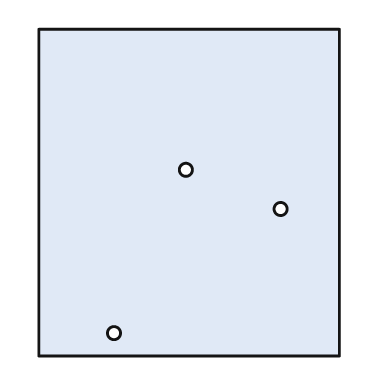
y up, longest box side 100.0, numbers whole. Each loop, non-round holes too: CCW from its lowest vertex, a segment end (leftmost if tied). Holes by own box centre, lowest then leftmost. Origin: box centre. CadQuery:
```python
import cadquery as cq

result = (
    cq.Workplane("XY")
    .moveTo(-46.0, -50.0)
    .lineTo(46.0, -50.0)
    .lineTo(46.0, 50.0)
    .lineTo(-46.0, 50.0)
    .close()
    .moveTo(-23.0, -43.0)
    .circle(2.0)
    .moveTo(28.0, -5.0)
    .circle(2.0)
    .moveTo(-1.0, 7.0)
    .circle(2.0)
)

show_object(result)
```